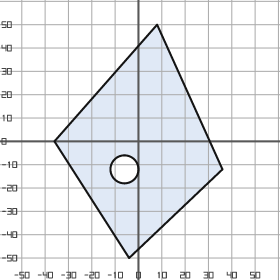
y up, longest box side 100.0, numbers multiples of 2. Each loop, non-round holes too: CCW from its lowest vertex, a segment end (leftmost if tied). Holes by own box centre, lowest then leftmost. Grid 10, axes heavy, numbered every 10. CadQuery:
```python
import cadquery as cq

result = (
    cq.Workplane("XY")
    .moveTo(-4.0, -50.0)
    .lineTo(36.0, -12.0)
    .lineTo(8.0, 50.0)
    .lineTo(-36.0, 0.0)
    .close()
    .moveTo(-6.0, -12.0)
    .circle(6.0)
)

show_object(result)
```